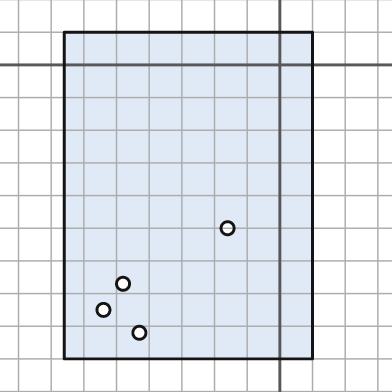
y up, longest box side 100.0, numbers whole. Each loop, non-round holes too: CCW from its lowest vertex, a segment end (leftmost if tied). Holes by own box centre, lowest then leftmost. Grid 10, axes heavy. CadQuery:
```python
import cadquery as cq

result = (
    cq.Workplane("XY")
    .moveTo(-66.0, -90.0)
    .lineTo(10.0, -90.0)
    .lineTo(10.0, 10.0)
    .lineTo(-66.0, 10.0)
    .close()
    .moveTo(-43.0, -82.0)
    .circle(2.0)
    .moveTo(-54.0, -75.0)
    .circle(2.0)
    .moveTo(-48.0, -67.0)
    .circle(2.0)
    .moveTo(-16.0, -50.0)
    .circle(2.0)
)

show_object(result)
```